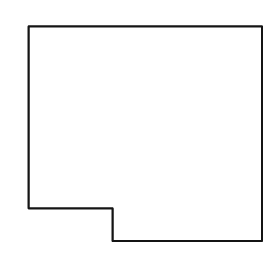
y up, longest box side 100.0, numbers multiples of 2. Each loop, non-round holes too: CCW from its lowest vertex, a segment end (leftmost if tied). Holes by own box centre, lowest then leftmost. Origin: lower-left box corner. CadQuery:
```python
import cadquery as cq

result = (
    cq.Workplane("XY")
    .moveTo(36.0, 0.0)
    .lineTo(100.0, 0.0)
    .lineTo(100.0, 92.0)
    .lineTo(0.0, 92.0)
    .lineTo(0.0, 14.0)
    .lineTo(36.0, 14.0)
    .close()
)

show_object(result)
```